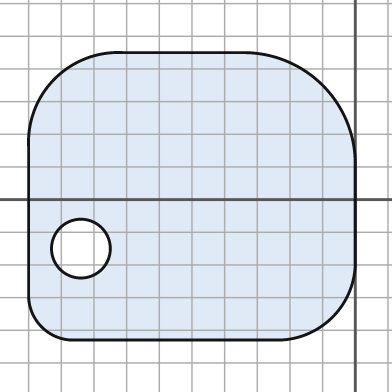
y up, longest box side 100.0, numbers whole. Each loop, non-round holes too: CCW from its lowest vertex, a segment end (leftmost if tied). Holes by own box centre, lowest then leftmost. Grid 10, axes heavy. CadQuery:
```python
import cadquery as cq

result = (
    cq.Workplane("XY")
    .moveTo(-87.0, -43.0)
    .lineTo(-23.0, -43.0)
    .threePointArc((-7.0, -36.0), (0.0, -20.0))
    .lineTo(0.0, 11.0)
    .threePointArc((-10.0, 35.0), (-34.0, 45.0))
    .lineTo(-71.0, 45.0)
    .threePointArc((-92.0, 37.0), (-100.0, 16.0))
    .lineTo(-100.0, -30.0)
    .threePointArc((-96.0, -39.0), (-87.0, -43.0))
    .close()
    .moveTo(-84.0, -15.0)
    .circle(9.0)
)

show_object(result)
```